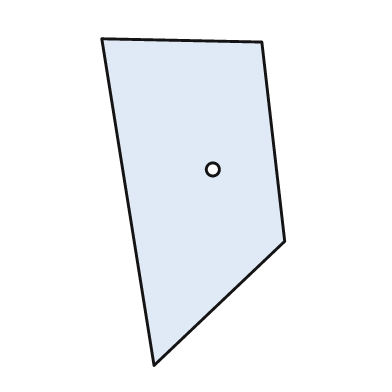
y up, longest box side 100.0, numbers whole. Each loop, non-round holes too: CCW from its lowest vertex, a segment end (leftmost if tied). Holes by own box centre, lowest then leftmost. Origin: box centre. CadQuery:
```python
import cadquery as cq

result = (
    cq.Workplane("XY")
    .moveTo(-12.0, -50.0)
    .lineTo(28.0, -12.0)
    .lineTo(21.0, 49.0)
    .lineTo(-28.0, 50.0)
    .close()
    .moveTo(6.0, 10.0)
    .circle(2.0)
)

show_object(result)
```